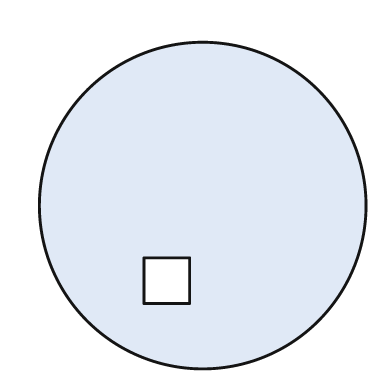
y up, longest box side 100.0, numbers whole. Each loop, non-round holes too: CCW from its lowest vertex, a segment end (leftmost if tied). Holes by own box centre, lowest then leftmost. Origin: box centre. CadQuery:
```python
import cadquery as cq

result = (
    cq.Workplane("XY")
    .moveTo(0.0, 0.0)
    .circle(50.0)
    .moveTo(-18.0, -30.0)
    .lineTo(-4.0, -30.0)
    .lineTo(-4.0, -16.0)
    .lineTo(-18.0, -16.0)
    .close()
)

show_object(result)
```